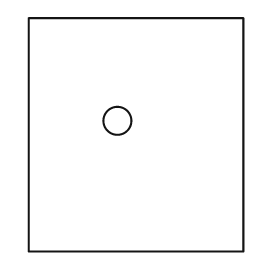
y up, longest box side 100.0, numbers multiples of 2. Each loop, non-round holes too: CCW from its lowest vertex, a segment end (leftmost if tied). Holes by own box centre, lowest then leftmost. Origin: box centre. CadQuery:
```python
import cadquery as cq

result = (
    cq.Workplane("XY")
    .moveTo(-46.0, -50.0)
    .lineTo(46.0, -50.0)
    .lineTo(46.0, 50.0)
    .lineTo(-46.0, 50.0)
    .close()
    .moveTo(-8.0, 6.0)
    .circle(6.0)
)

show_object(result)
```